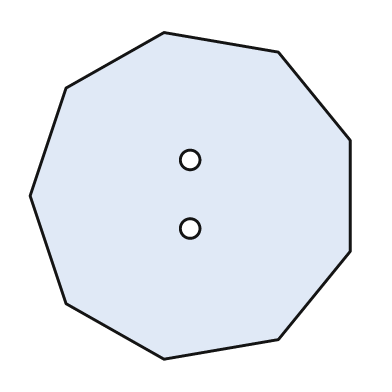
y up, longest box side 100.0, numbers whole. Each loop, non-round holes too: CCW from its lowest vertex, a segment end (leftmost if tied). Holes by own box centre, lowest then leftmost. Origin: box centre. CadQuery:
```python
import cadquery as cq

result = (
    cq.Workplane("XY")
    .moveTo(-8.0, -50.0)
    .lineTo(27.0, -44.0)
    .lineTo(49.0, -17.0)
    .lineTo(49.0, 17.0)
    .lineTo(27.0, 44.0)
    .lineTo(-8.0, 50.0)
    .lineTo(-38.0, 33.0)
    .lineTo(-49.0, 0.0)
    .lineTo(-38.0, -33.0)
    .close()
    .moveTo(0.0, -10.0)
    .circle(3.0)
    .moveTo(0.0, 11.0)
    .circle(3.0)
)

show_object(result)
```